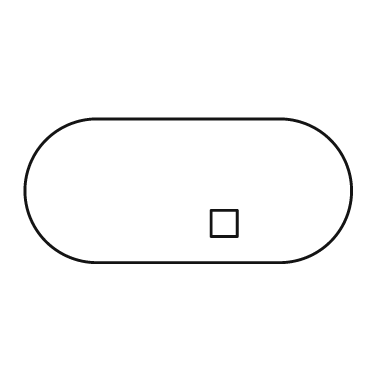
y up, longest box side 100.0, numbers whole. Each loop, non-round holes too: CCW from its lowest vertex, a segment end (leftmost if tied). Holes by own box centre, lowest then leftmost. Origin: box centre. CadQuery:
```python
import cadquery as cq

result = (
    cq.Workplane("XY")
    .moveTo(-28.0, -22.0)
    .lineTo(28.0, -22.0)
    .threePointArc((50.0, 0.0), (28.0, 22.0))
    .lineTo(-28.0, 22.0)
    .threePointArc((-50.0, 0.0), (-28.0, -22.0))
    .close()
    .moveTo(7.0, -14.0)
    .lineTo(15.0, -14.0)
    .lineTo(15.0, -6.0)
    .lineTo(7.0, -6.0)
    .close()
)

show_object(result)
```